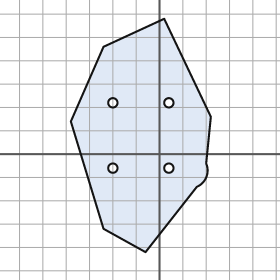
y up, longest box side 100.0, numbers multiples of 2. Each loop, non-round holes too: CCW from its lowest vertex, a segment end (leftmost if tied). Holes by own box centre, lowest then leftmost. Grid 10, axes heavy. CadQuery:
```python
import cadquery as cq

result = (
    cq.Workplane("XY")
    .moveTo(-6.0, -42.0)
    .lineTo(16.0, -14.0)
    .threePointArc((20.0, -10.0), (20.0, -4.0))
    .lineTo(22.0, 16.0)
    .lineTo(2.0, 58.0)
    .lineTo(-24.0, 46.0)
    .lineTo(-38.0, 14.0)
    .lineTo(-24.0, -32.0)
    .close()
    .moveTo(-20.0, -6.0)
    .circle(2.0)
    .moveTo(4.0, -6.0)
    .circle(2.0)
    .moveTo(-20.0, 22.0)
    .circle(2.0)
    .moveTo(4.0, 22.0)
    .circle(2.0)
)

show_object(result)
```